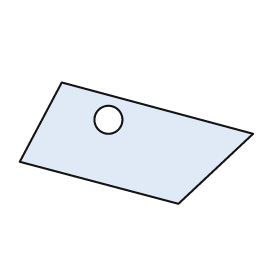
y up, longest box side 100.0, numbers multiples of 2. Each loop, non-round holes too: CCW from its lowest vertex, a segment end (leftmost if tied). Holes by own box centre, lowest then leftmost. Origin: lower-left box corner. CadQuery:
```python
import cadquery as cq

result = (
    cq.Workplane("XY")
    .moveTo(68.0, 0.0)
    .lineTo(100.0, 30.0)
    .lineTo(18.0, 52.0)
    .lineTo(0.0, 18.0)
    .close()
    .moveTo(38.0, 36.0)
    .circle(6.0)
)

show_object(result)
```